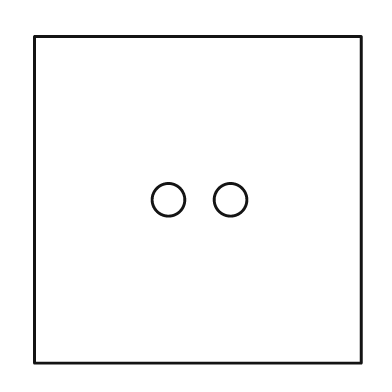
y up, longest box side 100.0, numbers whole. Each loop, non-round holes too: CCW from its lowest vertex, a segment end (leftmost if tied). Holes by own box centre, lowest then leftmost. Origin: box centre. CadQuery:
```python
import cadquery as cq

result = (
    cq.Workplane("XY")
    .moveTo(-50.0, -50.0)
    .lineTo(50.0, -50.0)
    .lineTo(50.0, 50.0)
    .lineTo(-50.0, 50.0)
    .close()
    .moveTo(-9.0, 0.0)
    .circle(5.0)
    .moveTo(10.0, 0.0)
    .circle(5.0)
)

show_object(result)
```